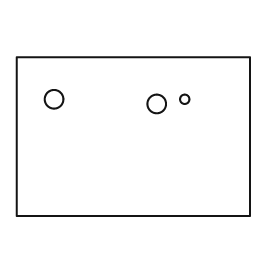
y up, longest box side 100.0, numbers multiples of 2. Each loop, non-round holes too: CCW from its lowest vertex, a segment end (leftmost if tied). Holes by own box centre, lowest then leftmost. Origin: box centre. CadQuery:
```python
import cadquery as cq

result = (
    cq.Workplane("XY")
    .moveTo(-50.0, -34.0)
    .lineTo(50.0, -34.0)
    .lineTo(50.0, 34.0)
    .lineTo(-50.0, 34.0)
    .close()
    .moveTo(10.0, 14.0)
    .circle(4.0)
    .moveTo(-34.0, 16.0)
    .circle(4.0)
    .moveTo(22.0, 16.0)
    .circle(2.0)
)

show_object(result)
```